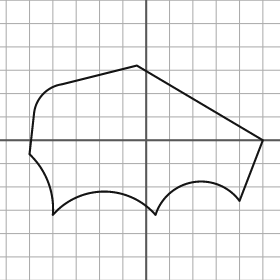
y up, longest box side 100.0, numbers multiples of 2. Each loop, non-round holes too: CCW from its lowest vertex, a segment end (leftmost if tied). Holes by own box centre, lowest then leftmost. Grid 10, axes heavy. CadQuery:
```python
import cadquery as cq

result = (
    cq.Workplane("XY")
    .moveTo(-40.0, -32.0)
    .threePointArc((-18.0, -22.0), (4.0, -32.0))
    .threePointArc((20.0, -18.0), (40.0, -26.0))
    .lineTo(50.0, 0.0)
    .lineTo(-4.0, 32.0)
    .lineTo(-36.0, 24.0)
    .threePointArc((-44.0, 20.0), (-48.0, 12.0))
    .lineTo(-50.0, -6.0)
    .threePointArc((-42.0, -18.0), (-40.0, -32.0))
    .close()
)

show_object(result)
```